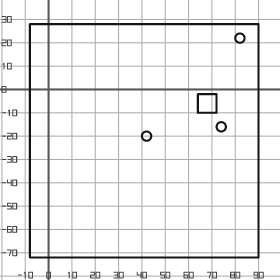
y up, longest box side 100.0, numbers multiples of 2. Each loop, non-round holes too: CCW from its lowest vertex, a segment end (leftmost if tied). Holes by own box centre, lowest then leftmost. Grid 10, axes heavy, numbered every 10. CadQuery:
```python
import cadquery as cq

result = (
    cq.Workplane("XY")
    .moveTo(-8.0, -72.0)
    .lineTo(90.0, -72.0)
    .lineTo(90.0, 28.0)
    .lineTo(-8.0, 28.0)
    .close()
    .moveTo(42.0, -20.0)
    .circle(2.0)
    .moveTo(74.0, -16.0)
    .circle(2.0)
    .moveTo(64.0, -10.0)
    .lineTo(72.0, -10.0)
    .lineTo(72.0, -2.0)
    .lineTo(64.0, -2.0)
    .close()
    .moveTo(82.0, 22.0)
    .circle(2.0)
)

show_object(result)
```